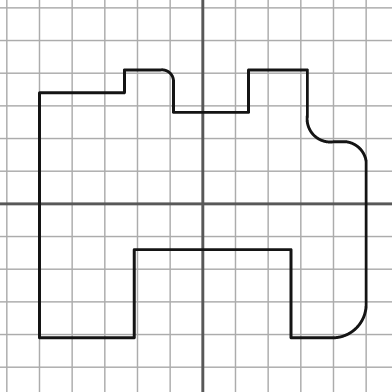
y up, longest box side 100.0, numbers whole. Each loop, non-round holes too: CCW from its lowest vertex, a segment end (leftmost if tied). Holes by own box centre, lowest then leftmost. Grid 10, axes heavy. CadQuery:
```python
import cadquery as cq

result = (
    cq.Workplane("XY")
    .moveTo(-50.0, -41.0)
    .lineTo(-21.0, -41.0)
    .lineTo(-21.0, -14.0)
    .lineTo(27.0, -14.0)
    .lineTo(27.0, -41.0)
    .lineTo(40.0, -41.0)
    .threePointArc((47.0, -38.0), (50.0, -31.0))
    .lineTo(50.0, 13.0)
    .threePointArc((48.0, 17.0), (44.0, 19.0))
    .lineTo(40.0, 19.0)
    .threePointArc((34.0, 21.0), (32.0, 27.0))
    .lineTo(32.0, 41.0)
    .lineTo(14.0, 41.0)
    .lineTo(14.0, 28.0)
    .lineTo(-9.0, 28.0)
    .lineTo(-9.0, 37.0)
    .threePointArc((-10.0, 40.0), (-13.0, 41.0))
    .lineTo(-24.0, 41.0)
    .lineTo(-24.0, 34.0)
    .lineTo(-50.0, 34.0)
    .close()
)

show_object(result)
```